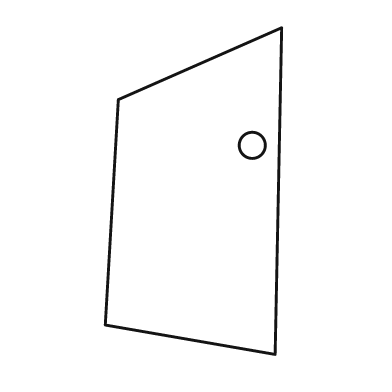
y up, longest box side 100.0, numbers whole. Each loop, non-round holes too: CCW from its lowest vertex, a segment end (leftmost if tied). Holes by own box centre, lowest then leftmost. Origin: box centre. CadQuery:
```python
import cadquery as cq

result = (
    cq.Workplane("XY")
    .moveTo(25.0, -50.0)
    .lineTo(27.0, 50.0)
    .lineTo(-23.0, 28.0)
    .lineTo(-27.0, -41.0)
    .close()
    .moveTo(18.0, 14.0)
    .circle(4.0)
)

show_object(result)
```